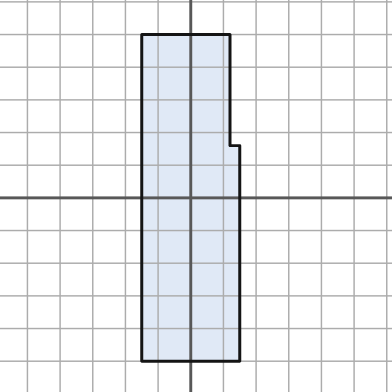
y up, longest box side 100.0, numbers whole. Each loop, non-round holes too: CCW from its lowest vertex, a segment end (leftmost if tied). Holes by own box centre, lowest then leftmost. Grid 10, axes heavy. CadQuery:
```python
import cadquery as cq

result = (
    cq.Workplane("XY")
    .moveTo(-15.0, -50.0)
    .lineTo(15.0, -50.0)
    .lineTo(15.0, 16.0)
    .lineTo(12.0, 16.0)
    .lineTo(12.0, 50.0)
    .lineTo(-15.0, 50.0)
    .close()
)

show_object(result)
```